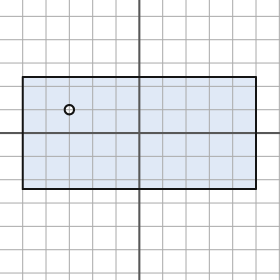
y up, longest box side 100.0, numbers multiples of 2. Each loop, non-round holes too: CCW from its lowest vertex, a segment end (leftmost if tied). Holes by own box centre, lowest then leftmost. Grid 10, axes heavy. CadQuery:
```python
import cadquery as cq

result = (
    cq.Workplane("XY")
    .moveTo(-50.0, -24.0)
    .lineTo(50.0, -24.0)
    .lineTo(50.0, 24.0)
    .lineTo(-50.0, 24.0)
    .close()
    .moveTo(-30.0, 10.0)
    .circle(2.0)
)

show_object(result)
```